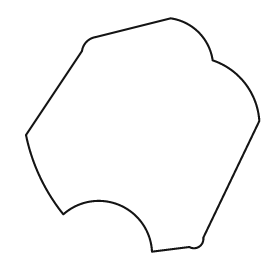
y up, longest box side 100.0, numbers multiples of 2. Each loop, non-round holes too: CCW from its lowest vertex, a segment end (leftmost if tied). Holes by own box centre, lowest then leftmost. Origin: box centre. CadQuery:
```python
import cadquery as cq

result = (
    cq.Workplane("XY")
    .moveTo(4.0, -50.0)
    .lineTo(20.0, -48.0)
    .threePointArc((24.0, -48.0), (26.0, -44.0))
    .lineTo(50.0, 6.0)
    .threePointArc((44.0, 22.0), (30.0, 32.0))
    .threePointArc((24.0, 44.0), (12.0, 50.0))
    .lineTo(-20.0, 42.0)
    .threePointArc((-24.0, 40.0), (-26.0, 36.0))
    .lineTo(-50.0, 0.0)
    .threePointArc((-44.0, -18.0), (-34.0, -34.0))
    .threePointArc((-10.0, -30.0), (4.0, -50.0))
    .close()
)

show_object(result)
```